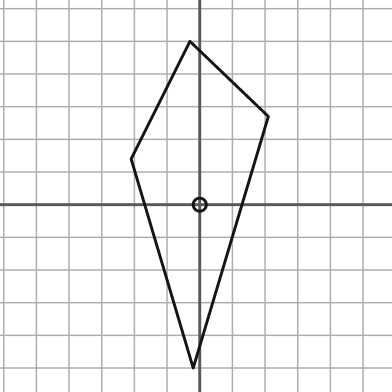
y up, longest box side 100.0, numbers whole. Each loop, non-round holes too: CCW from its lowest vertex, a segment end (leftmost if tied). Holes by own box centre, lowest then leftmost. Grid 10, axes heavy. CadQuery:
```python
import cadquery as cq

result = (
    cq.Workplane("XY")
    .moveTo(-2.0, -50.0)
    .lineTo(21.0, 27.0)
    .lineTo(-3.0, 50.0)
    .lineTo(-21.0, 14.0)
    .close()
    .moveTo(0.0, 0.0)
    .circle(2.0)
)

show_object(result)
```